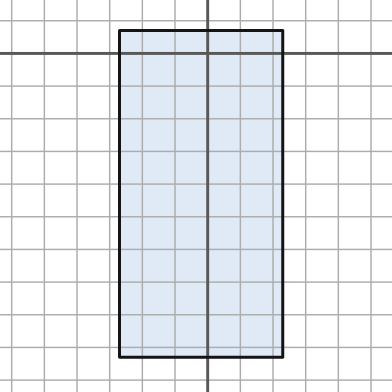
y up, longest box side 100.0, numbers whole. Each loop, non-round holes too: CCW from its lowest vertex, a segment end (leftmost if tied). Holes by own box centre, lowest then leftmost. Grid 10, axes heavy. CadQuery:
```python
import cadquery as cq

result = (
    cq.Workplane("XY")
    .moveTo(-27.0, -93.0)
    .lineTo(23.0, -93.0)
    .lineTo(23.0, 7.0)
    .lineTo(-27.0, 7.0)
    .close()
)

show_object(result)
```